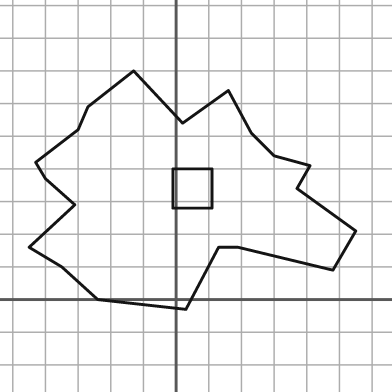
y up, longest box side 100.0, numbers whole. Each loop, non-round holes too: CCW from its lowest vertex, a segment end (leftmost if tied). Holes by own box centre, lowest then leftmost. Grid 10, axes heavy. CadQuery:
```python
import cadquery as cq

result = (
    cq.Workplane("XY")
    .moveTo(3.0, -3.0)
    .lineTo(13.0, 16.0)
    .lineTo(19.0, 16.0)
    .lineTo(48.0, 9.0)
    .lineTo(55.0, 21.0)
    .lineTo(37.0, 34.0)
    .lineTo(41.0, 41.0)
    .lineTo(30.0, 44.0)
    .lineTo(23.0, 51.0)
    .lineTo(16.0, 64.0)
    .lineTo(2.0, 54.0)
    .lineTo(-13.0, 70.0)
    .lineTo(-27.0, 59.0)
    .lineTo(-30.0, 52.0)
    .lineTo(-43.0, 42.0)
    .lineTo(-40.0, 37.0)
    .lineTo(-31.0, 29.0)
    .lineTo(-45.0, 16.0)
    .lineTo(-35.0, 10.0)
    .lineTo(-24.0, 0.0)
    .close()
    .moveTo(-1.0, 28.0)
    .lineTo(11.0, 28.0)
    .lineTo(11.0, 40.0)
    .lineTo(-1.0, 40.0)
    .close()
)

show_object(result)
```